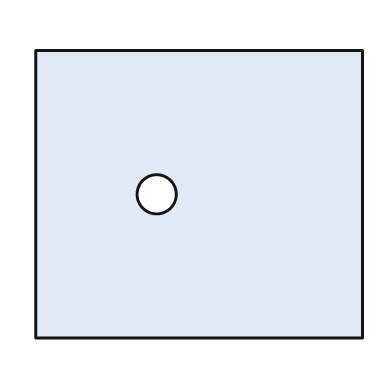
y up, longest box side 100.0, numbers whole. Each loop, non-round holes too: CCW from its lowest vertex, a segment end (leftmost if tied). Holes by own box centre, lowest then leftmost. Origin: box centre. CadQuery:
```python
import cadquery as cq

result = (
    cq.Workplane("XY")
    .moveTo(-50.0, -44.0)
    .lineTo(50.0, -44.0)
    .lineTo(50.0, 44.0)
    .lineTo(-50.0, 44.0)
    .close()
    .moveTo(-13.0, 0.0)
    .circle(6.0)
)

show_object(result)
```